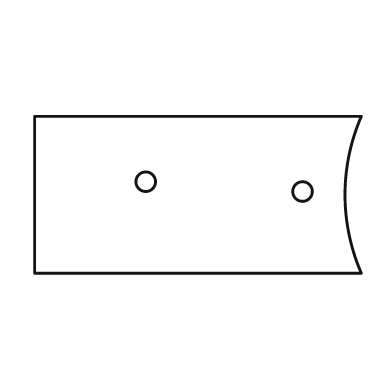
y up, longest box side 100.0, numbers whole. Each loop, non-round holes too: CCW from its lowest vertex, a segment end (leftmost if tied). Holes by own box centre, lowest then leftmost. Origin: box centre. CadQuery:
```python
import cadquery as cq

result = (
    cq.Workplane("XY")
    .moveTo(-50.0, -24.0)
    .lineTo(50.0, -24.0)
    .threePointArc((45.0, 0.0), (50.0, 24.0))
    .lineTo(-50.0, 24.0)
    .close()
    .moveTo(32.0, 1.0)
    .circle(3.0)
    .moveTo(-16.0, 4.0)
    .circle(3.0)
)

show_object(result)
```